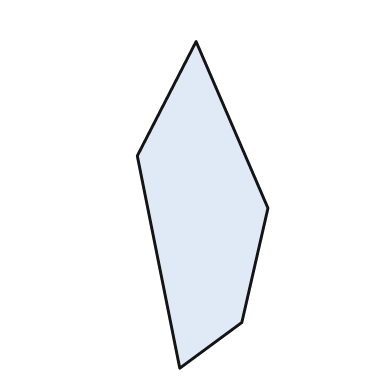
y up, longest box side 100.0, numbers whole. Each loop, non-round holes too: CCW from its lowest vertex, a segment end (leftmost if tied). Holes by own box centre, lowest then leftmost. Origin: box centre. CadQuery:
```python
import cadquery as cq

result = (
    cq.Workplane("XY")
    .moveTo(-7.0, -50.0)
    .lineTo(12.0, -36.0)
    .lineTo(20.0, -1.0)
    .lineTo(-2.0, 50.0)
    .lineTo(-20.0, 15.0)
    .close()
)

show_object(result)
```